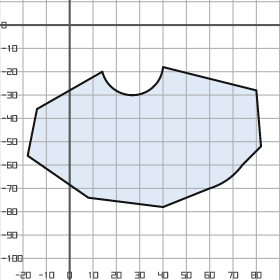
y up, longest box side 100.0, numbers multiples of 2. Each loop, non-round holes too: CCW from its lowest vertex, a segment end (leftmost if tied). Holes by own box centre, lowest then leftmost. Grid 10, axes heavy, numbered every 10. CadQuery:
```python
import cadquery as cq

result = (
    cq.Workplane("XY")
    .moveTo(40.0, -78.0)
    .lineTo(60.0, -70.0)
    .threePointArc((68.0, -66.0), (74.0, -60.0))
    .lineTo(82.0, -52.0)
    .lineTo(80.0, -28.0)
    .lineTo(40.0, -18.0)
    .threePointArc((28.0, -30.0), (14.0, -20.0))
    .lineTo(-14.0, -36.0)
    .lineTo(-18.0, -56.0)
    .lineTo(8.0, -74.0)
    .close()
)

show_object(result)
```